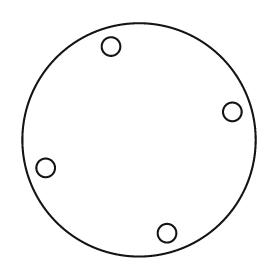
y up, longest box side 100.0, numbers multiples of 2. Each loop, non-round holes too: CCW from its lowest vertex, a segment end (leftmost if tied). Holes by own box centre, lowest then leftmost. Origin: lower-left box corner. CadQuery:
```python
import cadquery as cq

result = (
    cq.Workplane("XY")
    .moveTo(50.0, 50.0)
    .circle(50.0)
    .moveTo(62.0, 10.0)
    .circle(4.0)
    .moveTo(10.0, 38.0)
    .circle(4.0)
    .moveTo(90.0, 62.0)
    .circle(4.0)
    .moveTo(38.0, 90.0)
    .circle(4.0)
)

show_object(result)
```